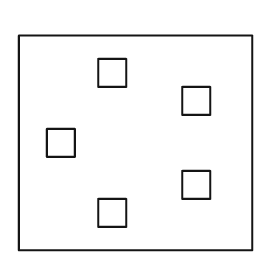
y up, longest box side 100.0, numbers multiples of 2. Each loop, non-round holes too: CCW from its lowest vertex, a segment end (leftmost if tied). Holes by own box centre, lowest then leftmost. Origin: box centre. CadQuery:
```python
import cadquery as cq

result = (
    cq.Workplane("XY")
    .moveTo(-50.0, -46.0)
    .lineTo(50.0, -46.0)
    .lineTo(50.0, 46.0)
    .lineTo(-50.0, 46.0)
    .close()
    .moveTo(-16.0, -36.0)
    .lineTo(-4.0, -36.0)
    .lineTo(-4.0, -24.0)
    .lineTo(-16.0, -24.0)
    .close()
    .moveTo(20.0, -24.0)
    .lineTo(32.0, -24.0)
    .lineTo(32.0, -12.0)
    .lineTo(20.0, -12.0)
    .close()
    .moveTo(-38.0, -6.0)
    .lineTo(-26.0, -6.0)
    .lineTo(-26.0, 6.0)
    .lineTo(-38.0, 6.0)
    .close()
    .moveTo(20.0, 12.0)
    .lineTo(32.0, 12.0)
    .lineTo(32.0, 24.0)
    .lineTo(20.0, 24.0)
    .close()
    .moveTo(-16.0, 24.0)
    .lineTo(-4.0, 24.0)
    .lineTo(-4.0, 36.0)
    .lineTo(-16.0, 36.0)
    .close()
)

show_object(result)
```